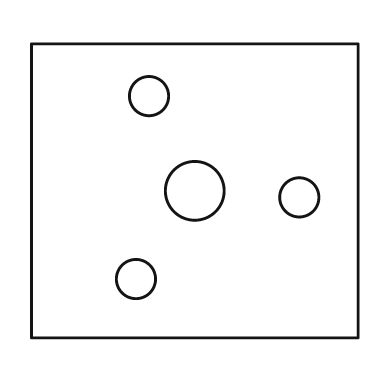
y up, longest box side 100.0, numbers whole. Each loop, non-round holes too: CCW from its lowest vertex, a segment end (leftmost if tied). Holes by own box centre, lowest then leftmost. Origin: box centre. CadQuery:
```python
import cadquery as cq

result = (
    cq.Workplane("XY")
    .moveTo(-50.0, -45.0)
    .lineTo(50.0, -45.0)
    .lineTo(50.0, 45.0)
    .lineTo(-50.0, 45.0)
    .close()
    .moveTo(-18.0, -27.0)
    .circle(6.0)
    .moveTo(32.0, -2.0)
    .circle(6.0)
    .moveTo(0.0, 0.0)
    .circle(9.0)
    .moveTo(-14.0, 29.0)
    .circle(6.0)
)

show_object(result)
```